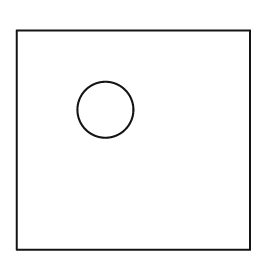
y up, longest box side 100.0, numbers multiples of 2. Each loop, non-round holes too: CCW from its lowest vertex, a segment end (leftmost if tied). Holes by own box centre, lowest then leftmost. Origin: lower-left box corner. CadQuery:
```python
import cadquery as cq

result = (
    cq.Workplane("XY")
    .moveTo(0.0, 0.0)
    .lineTo(100.0, 0.0)
    .lineTo(100.0, 94.0)
    .lineTo(0.0, 94.0)
    .close()
    .moveTo(38.0, 60.0)
    .circle(12.0)
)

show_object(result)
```